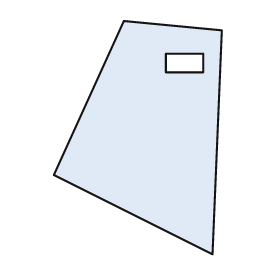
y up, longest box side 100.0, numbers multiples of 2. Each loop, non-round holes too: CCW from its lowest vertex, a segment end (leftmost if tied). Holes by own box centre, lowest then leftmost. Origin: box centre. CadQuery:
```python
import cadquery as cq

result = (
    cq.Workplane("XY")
    .moveTo(32.0, -50.0)
    .lineTo(36.0, 46.0)
    .lineTo(-6.0, 50.0)
    .lineTo(-36.0, -16.0)
    .close()
    .moveTo(12.0, 28.0)
    .lineTo(28.0, 28.0)
    .lineTo(28.0, 36.0)
    .lineTo(12.0, 36.0)
    .close()
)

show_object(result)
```